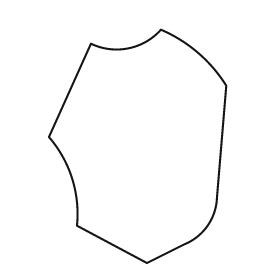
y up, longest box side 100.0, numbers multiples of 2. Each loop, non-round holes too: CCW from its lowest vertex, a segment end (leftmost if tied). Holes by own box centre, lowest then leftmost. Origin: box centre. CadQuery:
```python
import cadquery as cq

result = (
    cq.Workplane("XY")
    .moveTo(4.0, -50.0)
    .lineTo(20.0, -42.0)
    .threePointArc((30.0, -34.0), (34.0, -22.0))
    .lineTo(38.0, 26.0)
    .threePointArc((26.0, 40.0), (10.0, 50.0))
    .threePointArc((-4.0, 42.0), (-20.0, 44.0))
    .lineTo(-38.0, 4.0)
    .threePointArc((-28.0, -14.0), (-26.0, -34.0))
    .close()
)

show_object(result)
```